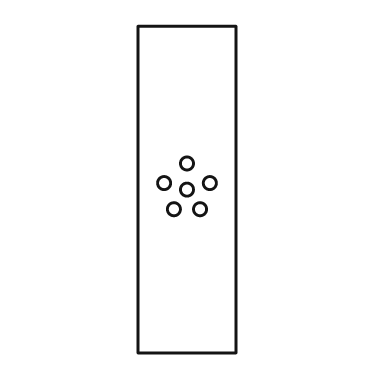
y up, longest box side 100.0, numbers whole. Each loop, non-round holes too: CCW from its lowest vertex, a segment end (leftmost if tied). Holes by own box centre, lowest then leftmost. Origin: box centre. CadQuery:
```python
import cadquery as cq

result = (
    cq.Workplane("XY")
    .moveTo(-15.0, -50.0)
    .lineTo(15.0, -50.0)
    .lineTo(15.0, 50.0)
    .lineTo(-15.0, 50.0)
    .close()
    .moveTo(-4.0, -6.0)
    .circle(2.0)
    .moveTo(4.0, -6.0)
    .circle(2.0)
    .moveTo(0.0, 0.0)
    .circle(2.0)
    .moveTo(-7.0, 2.0)
    .circle(2.0)
    .moveTo(7.0, 2.0)
    .circle(2.0)
    .moveTo(0.0, 8.0)
    .circle(2.0)
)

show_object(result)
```